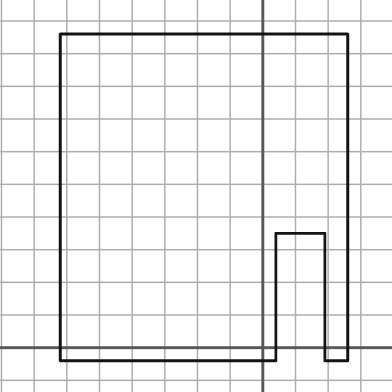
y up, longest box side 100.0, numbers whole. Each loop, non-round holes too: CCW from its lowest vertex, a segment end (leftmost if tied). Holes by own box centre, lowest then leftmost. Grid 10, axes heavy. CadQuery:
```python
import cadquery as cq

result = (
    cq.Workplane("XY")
    .moveTo(-62.0, -4.0)
    .lineTo(4.0, -4.0)
    .lineTo(4.0, 35.0)
    .lineTo(19.0, 35.0)
    .lineTo(19.0, -4.0)
    .lineTo(26.0, -4.0)
    .lineTo(26.0, 96.0)
    .lineTo(-62.0, 96.0)
    .close()
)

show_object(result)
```